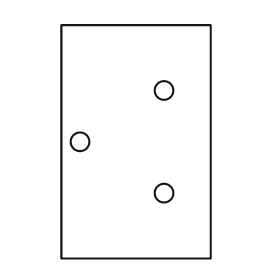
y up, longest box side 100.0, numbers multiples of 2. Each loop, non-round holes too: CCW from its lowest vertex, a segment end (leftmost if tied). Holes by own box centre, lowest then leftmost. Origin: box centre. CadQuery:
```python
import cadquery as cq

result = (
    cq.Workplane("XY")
    .moveTo(-32.0, -50.0)
    .lineTo(32.0, -50.0)
    .lineTo(32.0, 50.0)
    .lineTo(-32.0, 50.0)
    .close()
    .moveTo(12.0, -22.0)
    .circle(4.0)
    .moveTo(-24.0, 0.0)
    .circle(4.0)
    .moveTo(12.0, 22.0)
    .circle(4.0)
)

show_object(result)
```